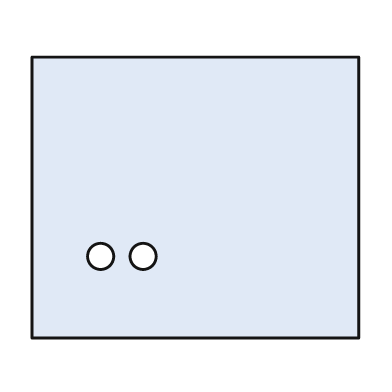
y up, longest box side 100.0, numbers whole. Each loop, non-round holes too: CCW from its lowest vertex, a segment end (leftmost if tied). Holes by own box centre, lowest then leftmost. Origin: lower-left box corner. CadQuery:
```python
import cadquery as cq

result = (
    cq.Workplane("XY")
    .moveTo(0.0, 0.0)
    .lineTo(100.0, 0.0)
    .lineTo(100.0, 86.0)
    .lineTo(0.0, 86.0)
    .close()
    .moveTo(21.0, 25.0)
    .circle(4.0)
    .moveTo(34.0, 25.0)
    .circle(4.0)
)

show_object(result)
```